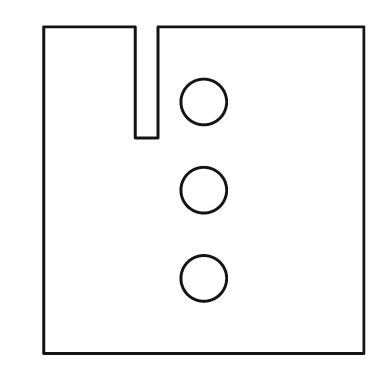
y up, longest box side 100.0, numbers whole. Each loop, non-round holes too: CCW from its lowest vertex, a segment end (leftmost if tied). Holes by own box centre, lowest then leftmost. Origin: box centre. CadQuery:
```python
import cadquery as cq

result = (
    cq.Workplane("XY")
    .moveTo(-49.0, -50.0)
    .lineTo(49.0, -50.0)
    .lineTo(49.0, 50.0)
    .lineTo(-14.0, 50.0)
    .lineTo(-14.0, 16.0)
    .lineTo(-21.0, 16.0)
    .lineTo(-21.0, 50.0)
    .lineTo(-49.0, 50.0)
    .close()
    .moveTo(0.0, -27.0)
    .circle(7.0)
    .moveTo(0.0, 0.0)
    .circle(7.0)
    .moveTo(0.0, 27.0)
    .circle(7.0)
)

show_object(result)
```